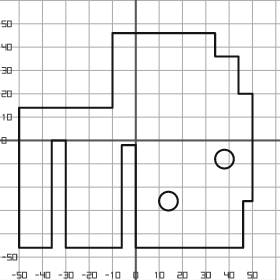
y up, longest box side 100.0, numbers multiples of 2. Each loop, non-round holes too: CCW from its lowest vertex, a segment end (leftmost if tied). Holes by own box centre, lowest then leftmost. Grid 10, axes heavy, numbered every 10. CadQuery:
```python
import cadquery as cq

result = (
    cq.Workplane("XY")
    .moveTo(-50.0, -46.0)
    .lineTo(-36.0, -46.0)
    .lineTo(-36.0, 0.0)
    .lineTo(-30.0, 0.0)
    .lineTo(-30.0, -46.0)
    .lineTo(-6.0, -46.0)
    .lineTo(-6.0, -2.0)
    .lineTo(0.0, -2.0)
    .lineTo(0.0, -46.0)
    .lineTo(46.0, -46.0)
    .lineTo(46.0, -26.0)
    .lineTo(50.0, -26.0)
    .lineTo(50.0, 20.0)
    .lineTo(44.0, 20.0)
    .lineTo(44.0, 36.0)
    .lineTo(34.0, 36.0)
    .lineTo(34.0, 46.0)
    .lineTo(-10.0, 46.0)
    .lineTo(-10.0, 14.0)
    .lineTo(-50.0, 14.0)
    .close()
    .moveTo(14.0, -26.0)
    .circle(4.0)
    .moveTo(38.0, -8.0)
    .circle(4.0)
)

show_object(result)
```